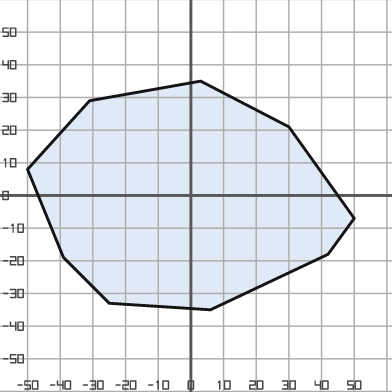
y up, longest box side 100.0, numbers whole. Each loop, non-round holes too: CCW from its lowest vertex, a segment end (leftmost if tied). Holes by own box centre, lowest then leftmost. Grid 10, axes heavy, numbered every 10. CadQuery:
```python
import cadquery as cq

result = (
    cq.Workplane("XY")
    .moveTo(6.0, -35.0)
    .lineTo(42.0, -18.0)
    .lineTo(50.0, -7.0)
    .lineTo(30.0, 21.0)
    .lineTo(3.0, 35.0)
    .lineTo(-31.0, 29.0)
    .lineTo(-50.0, 8.0)
    .lineTo(-39.0, -19.0)
    .lineTo(-25.0, -33.0)
    .close()
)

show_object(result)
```